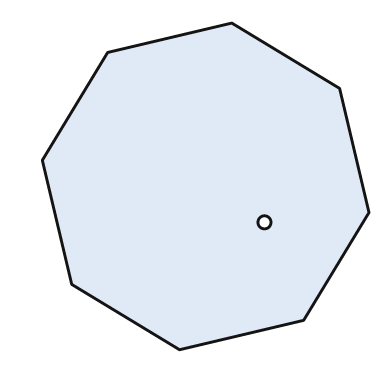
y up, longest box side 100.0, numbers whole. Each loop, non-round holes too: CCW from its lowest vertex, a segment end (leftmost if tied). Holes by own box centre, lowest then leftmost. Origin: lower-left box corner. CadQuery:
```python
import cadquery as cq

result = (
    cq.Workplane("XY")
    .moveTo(42.0, 0.0)
    .lineTo(80.0, 9.0)
    .lineTo(100.0, 42.0)
    .lineTo(91.0, 80.0)
    .lineTo(58.0, 100.0)
    .lineTo(20.0, 91.0)
    .lineTo(0.0, 58.0)
    .lineTo(9.0, 20.0)
    .close()
    .moveTo(68.0, 39.0)
    .circle(2.0)
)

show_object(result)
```